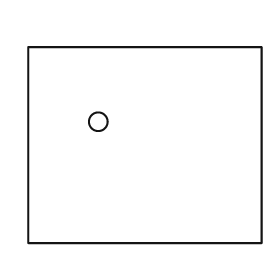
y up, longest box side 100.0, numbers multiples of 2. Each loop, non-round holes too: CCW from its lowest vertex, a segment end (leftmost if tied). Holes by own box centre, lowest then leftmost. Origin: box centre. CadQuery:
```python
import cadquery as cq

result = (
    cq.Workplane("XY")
    .moveTo(-50.0, -42.0)
    .lineTo(50.0, -42.0)
    .lineTo(50.0, 42.0)
    .lineTo(-50.0, 42.0)
    .close()
    .moveTo(-20.0, 10.0)
    .circle(4.0)
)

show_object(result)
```